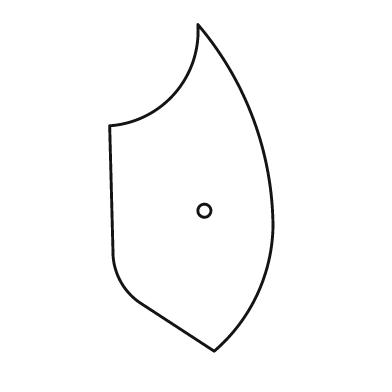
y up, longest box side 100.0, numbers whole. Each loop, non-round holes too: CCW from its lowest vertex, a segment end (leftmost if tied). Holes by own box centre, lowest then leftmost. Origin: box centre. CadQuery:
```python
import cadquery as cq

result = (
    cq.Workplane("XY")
    .moveTo(7.0, -50.0)
    .threePointArc((20.0, -33.0), (25.0, -12.0))
    .threePointArc((19.0, 21.0), (2.0, 50.0))
    .threePointArc((-5.0, 29.0), (-25.0, 19.0))
    .lineTo(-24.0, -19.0)
    .threePointArc((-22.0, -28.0), (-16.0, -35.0))
    .close()
    .moveTo(4.0, -7.0)
    .circle(2.0)
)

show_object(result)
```